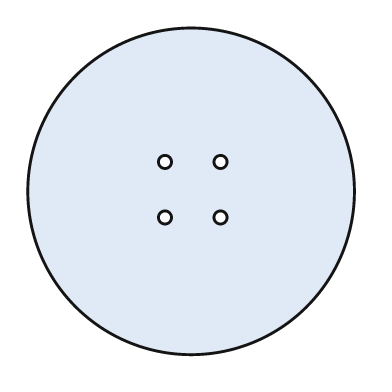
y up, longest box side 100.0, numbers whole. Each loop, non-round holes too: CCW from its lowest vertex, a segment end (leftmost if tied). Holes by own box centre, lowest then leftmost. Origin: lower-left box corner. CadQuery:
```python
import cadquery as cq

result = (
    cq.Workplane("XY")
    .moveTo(50.0, 50.0)
    .circle(50.0)
    .moveTo(42.0, 42.0)
    .circle(2.0)
    .moveTo(59.0, 42.0)
    .circle(2.0)
    .moveTo(42.0, 59.0)
    .circle(2.0)
    .moveTo(59.0, 59.0)
    .circle(2.0)
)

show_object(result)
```